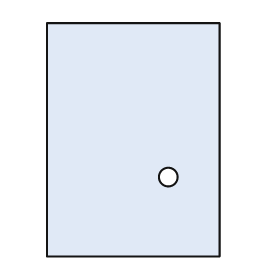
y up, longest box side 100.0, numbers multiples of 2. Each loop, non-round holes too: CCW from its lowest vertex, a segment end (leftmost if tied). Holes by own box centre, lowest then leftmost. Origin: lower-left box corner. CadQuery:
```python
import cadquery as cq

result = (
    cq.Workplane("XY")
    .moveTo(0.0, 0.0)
    .lineTo(74.0, 0.0)
    .lineTo(74.0, 100.0)
    .lineTo(0.0, 100.0)
    .close()
    .moveTo(52.0, 34.0)
    .circle(4.0)
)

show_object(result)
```